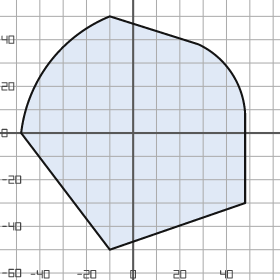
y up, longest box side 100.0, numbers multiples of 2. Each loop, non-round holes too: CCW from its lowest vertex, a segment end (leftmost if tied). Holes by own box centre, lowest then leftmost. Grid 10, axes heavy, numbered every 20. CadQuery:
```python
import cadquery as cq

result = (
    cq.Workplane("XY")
    .moveTo(-10.0, -50.0)
    .lineTo(48.0, -30.0)
    .lineTo(48.0, 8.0)
    .threePointArc((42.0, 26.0), (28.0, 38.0))
    .lineTo(-10.0, 50.0)
    .threePointArc((-36.0, 30.0), (-48.0, 0.0))
    .close()
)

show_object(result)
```